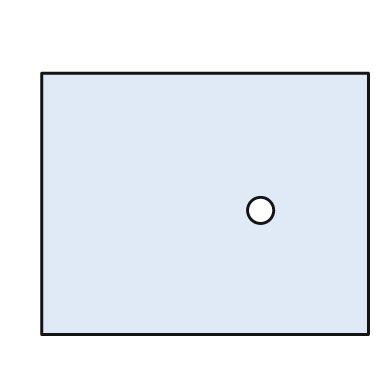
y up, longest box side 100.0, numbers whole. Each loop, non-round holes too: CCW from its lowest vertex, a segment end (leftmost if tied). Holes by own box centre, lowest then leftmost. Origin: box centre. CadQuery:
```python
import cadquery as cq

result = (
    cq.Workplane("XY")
    .moveTo(-50.0, -40.0)
    .lineTo(50.0, -40.0)
    .lineTo(50.0, 40.0)
    .lineTo(-50.0, 40.0)
    .close()
    .moveTo(17.0, -2.0)
    .circle(4.0)
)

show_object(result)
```